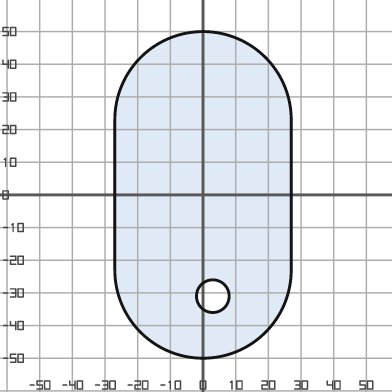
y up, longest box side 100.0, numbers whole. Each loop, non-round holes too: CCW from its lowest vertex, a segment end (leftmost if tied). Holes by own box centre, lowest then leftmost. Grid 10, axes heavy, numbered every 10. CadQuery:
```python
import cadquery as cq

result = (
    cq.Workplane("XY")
    .moveTo(-27.0, -23.0)
    .threePointArc((0.0, -50.0), (27.0, -23.0))
    .lineTo(27.0, 23.0)
    .threePointArc((0.0, 50.0), (-27.0, 23.0))
    .close()
    .moveTo(3.0, -31.0)
    .circle(5.0)
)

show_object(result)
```